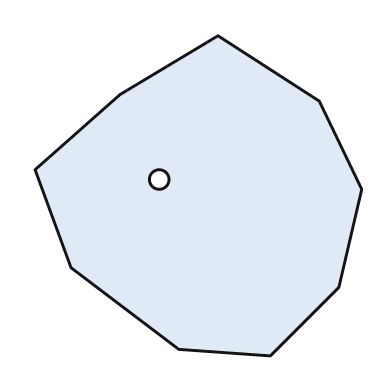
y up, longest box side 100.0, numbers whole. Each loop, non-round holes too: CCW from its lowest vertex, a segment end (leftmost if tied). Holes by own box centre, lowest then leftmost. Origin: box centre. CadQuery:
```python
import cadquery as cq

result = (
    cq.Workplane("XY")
    .moveTo(22.0, -49.0)
    .lineTo(43.0, -28.0)
    .lineTo(50.0, 2.0)
    .lineTo(37.0, 29.0)
    .lineTo(6.0, 49.0)
    .lineTo(-24.0, 31.0)
    .lineTo(-50.0, 8.0)
    .lineTo(-39.0, -22.0)
    .lineTo(-6.0, -47.0)
    .close()
    .moveTo(-12.0, 5.0)
    .circle(3.0)
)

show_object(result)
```